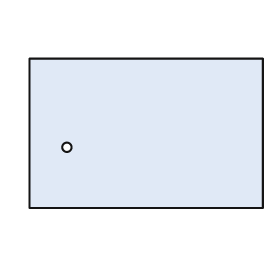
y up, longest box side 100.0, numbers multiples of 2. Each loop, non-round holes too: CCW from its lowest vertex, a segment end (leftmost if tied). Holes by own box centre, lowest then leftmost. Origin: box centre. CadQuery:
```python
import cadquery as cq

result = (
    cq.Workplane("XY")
    .moveTo(-50.0, -32.0)
    .lineTo(50.0, -32.0)
    .lineTo(50.0, 32.0)
    .lineTo(-50.0, 32.0)
    .close()
    .moveTo(-34.0, -6.0)
    .circle(2.0)
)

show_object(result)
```